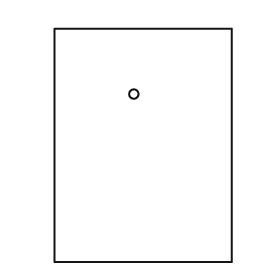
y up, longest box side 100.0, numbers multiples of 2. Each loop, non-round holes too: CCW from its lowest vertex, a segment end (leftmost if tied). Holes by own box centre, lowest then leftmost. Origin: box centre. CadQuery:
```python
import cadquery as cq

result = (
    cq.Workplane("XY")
    .moveTo(-38.0, -50.0)
    .lineTo(38.0, -50.0)
    .lineTo(38.0, 50.0)
    .lineTo(-38.0, 50.0)
    .close()
    .moveTo(-4.0, 22.0)
    .circle(2.0)
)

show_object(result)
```